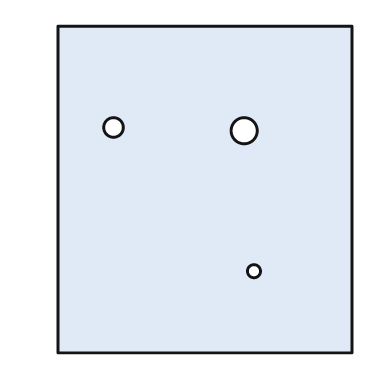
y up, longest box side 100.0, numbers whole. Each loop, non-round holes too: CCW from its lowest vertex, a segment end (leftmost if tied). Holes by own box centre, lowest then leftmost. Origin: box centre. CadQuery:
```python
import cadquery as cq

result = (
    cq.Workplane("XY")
    .moveTo(-45.0, -50.0)
    .lineTo(45.0, -50.0)
    .lineTo(45.0, 50.0)
    .lineTo(-45.0, 50.0)
    .close()
    .moveTo(15.0, -25.0)
    .circle(2.0)
    .moveTo(12.0, 18.0)
    .circle(4.0)
    .moveTo(-28.0, 19.0)
    .circle(3.0)
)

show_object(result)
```